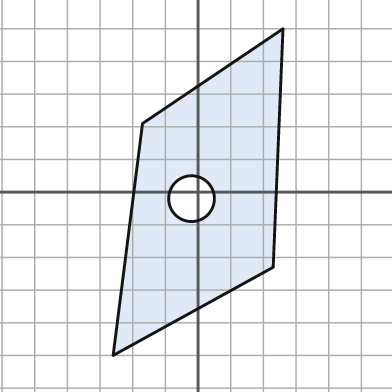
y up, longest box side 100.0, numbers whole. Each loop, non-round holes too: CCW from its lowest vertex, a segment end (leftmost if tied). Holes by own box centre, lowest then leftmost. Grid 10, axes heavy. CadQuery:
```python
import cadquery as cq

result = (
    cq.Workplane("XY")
    .moveTo(-26.0, -50.0)
    .lineTo(23.0, -23.0)
    .lineTo(26.0, 50.0)
    .lineTo(-17.0, 21.0)
    .close()
    .moveTo(-2.0, -2.0)
    .circle(7.0)
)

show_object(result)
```